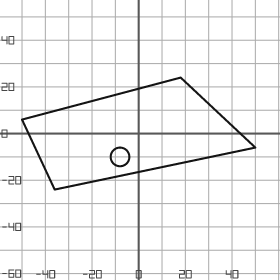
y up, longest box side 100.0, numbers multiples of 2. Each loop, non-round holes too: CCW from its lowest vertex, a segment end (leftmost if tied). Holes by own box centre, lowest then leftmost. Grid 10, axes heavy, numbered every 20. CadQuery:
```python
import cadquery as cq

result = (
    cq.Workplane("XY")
    .moveTo(-36.0, -24.0)
    .lineTo(50.0, -6.0)
    .lineTo(18.0, 24.0)
    .lineTo(-50.0, 6.0)
    .close()
    .moveTo(-8.0, -10.0)
    .circle(4.0)
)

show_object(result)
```